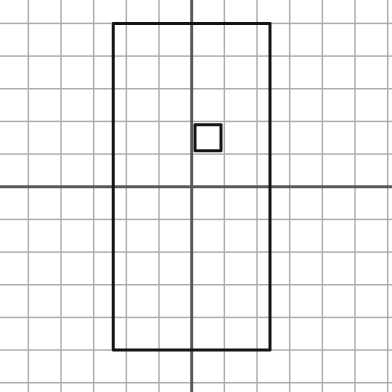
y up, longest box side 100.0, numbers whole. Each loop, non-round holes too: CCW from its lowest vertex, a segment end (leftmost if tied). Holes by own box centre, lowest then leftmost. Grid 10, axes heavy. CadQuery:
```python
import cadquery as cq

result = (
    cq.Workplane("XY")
    .moveTo(-24.0, -50.0)
    .lineTo(24.0, -50.0)
    .lineTo(24.0, 50.0)
    .lineTo(-24.0, 50.0)
    .close()
    .moveTo(1.0, 11.0)
    .lineTo(9.0, 11.0)
    .lineTo(9.0, 19.0)
    .lineTo(1.0, 19.0)
    .close()
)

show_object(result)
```